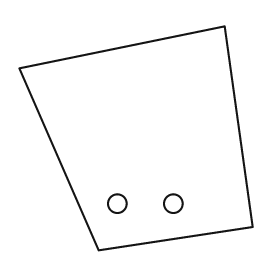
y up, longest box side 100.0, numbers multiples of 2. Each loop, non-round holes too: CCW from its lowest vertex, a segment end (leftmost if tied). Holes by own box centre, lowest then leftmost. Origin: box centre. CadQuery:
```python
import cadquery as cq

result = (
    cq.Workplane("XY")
    .moveTo(-16.0, -48.0)
    .lineTo(50.0, -38.0)
    .lineTo(38.0, 48.0)
    .lineTo(-50.0, 30.0)
    .close()
    .moveTo(-8.0, -28.0)
    .circle(4.0)
    .moveTo(16.0, -28.0)
    .circle(4.0)
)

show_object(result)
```